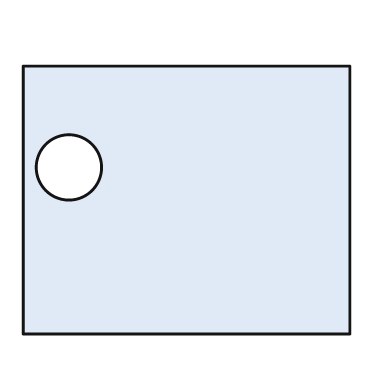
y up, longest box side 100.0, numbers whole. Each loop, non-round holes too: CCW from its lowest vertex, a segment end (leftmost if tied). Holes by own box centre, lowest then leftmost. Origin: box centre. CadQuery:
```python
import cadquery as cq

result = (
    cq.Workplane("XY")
    .moveTo(-50.0, -41.0)
    .lineTo(50.0, -41.0)
    .lineTo(50.0, 41.0)
    .lineTo(-50.0, 41.0)
    .close()
    .moveTo(-36.0, 10.0)
    .circle(10.0)
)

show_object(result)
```